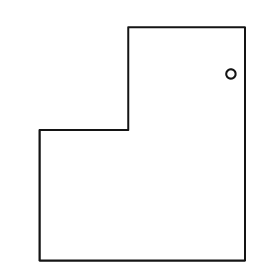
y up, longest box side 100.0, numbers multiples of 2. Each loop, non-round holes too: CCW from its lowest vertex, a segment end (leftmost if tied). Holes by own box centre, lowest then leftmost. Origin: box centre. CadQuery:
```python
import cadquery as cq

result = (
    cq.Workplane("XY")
    .moveTo(-44.0, -50.0)
    .lineTo(44.0, -50.0)
    .lineTo(44.0, 50.0)
    .lineTo(-6.0, 50.0)
    .lineTo(-6.0, 6.0)
    .lineTo(-44.0, 6.0)
    .close()
    .moveTo(38.0, 30.0)
    .circle(2.0)
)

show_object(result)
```